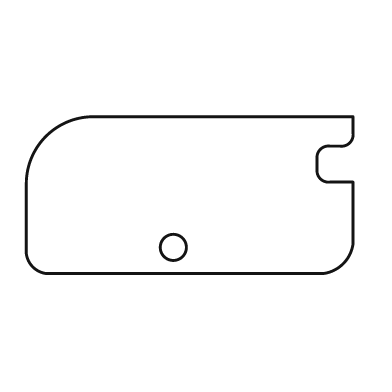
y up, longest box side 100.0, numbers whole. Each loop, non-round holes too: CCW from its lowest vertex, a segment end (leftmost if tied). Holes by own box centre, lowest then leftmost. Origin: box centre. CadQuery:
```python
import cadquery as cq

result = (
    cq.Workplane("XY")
    .moveTo(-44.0, -24.0)
    .lineTo(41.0, -24.0)
    .threePointArc((47.0, -21.0), (50.0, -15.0))
    .lineTo(50.0, 4.0)
    .lineTo(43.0, 4.0)
    .threePointArc((40.0, 5.0), (39.0, 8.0))
    .lineTo(39.0, 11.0)
    .threePointArc((40.0, 14.0), (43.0, 15.0))
    .lineTo(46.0, 15.0)
    .threePointArc((49.0, 16.0), (50.0, 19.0))
    .lineTo(50.0, 24.0)
    .lineTo(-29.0, 24.0)
    .threePointArc((-44.0, 18.0), (-50.0, 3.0))
    .lineTo(-50.0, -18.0)
    .threePointArc((-48.0, -22.0), (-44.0, -24.0))
    .close()
    .moveTo(-5.0, -16.0)
    .circle(4.0)
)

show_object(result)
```